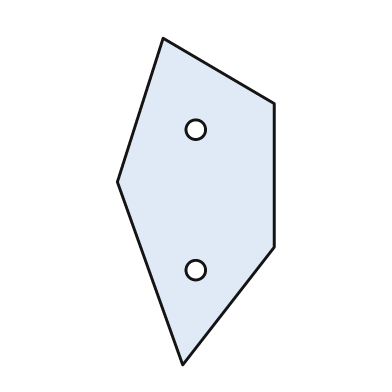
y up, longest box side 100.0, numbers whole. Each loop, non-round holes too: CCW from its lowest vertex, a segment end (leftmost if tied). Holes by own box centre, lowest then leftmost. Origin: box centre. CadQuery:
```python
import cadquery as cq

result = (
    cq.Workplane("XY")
    .moveTo(-4.0, -50.0)
    .lineTo(24.0, -14.0)
    .lineTo(24.0, 30.0)
    .lineTo(-10.0, 50.0)
    .lineTo(-24.0, 6.0)
    .close()
    .moveTo(0.0, -21.0)
    .circle(3.0)
    .moveTo(0.0, 22.0)
    .circle(3.0)
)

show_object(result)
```